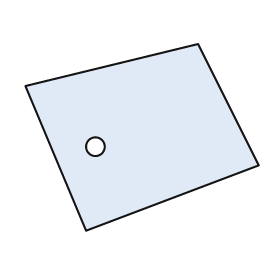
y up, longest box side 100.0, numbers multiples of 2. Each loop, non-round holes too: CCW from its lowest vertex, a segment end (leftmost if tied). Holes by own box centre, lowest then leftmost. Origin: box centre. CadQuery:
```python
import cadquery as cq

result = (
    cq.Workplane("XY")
    .moveTo(-24.0, -40.0)
    .lineTo(50.0, -12.0)
    .lineTo(24.0, 40.0)
    .lineTo(-50.0, 22.0)
    .close()
    .moveTo(-20.0, -4.0)
    .circle(4.0)
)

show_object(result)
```